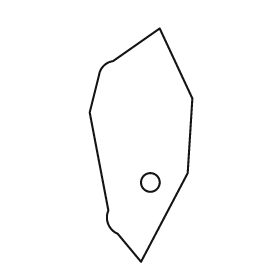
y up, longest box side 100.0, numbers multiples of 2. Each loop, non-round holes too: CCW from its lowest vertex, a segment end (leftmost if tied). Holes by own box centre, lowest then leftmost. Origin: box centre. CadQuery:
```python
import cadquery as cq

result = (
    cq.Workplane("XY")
    .moveTo(0.0, -50.0)
    .lineTo(20.0, -12.0)
    .lineTo(22.0, 20.0)
    .lineTo(8.0, 50.0)
    .lineTo(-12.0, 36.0)
    .threePointArc((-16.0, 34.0), (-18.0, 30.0))
    .lineTo(-22.0, 14.0)
    .lineTo(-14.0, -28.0)
    .threePointArc((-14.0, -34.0), (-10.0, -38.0))
    .close()
    .moveTo(4.0, -16.0)
    .circle(4.0)
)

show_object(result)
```